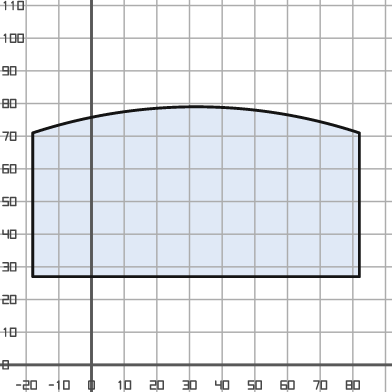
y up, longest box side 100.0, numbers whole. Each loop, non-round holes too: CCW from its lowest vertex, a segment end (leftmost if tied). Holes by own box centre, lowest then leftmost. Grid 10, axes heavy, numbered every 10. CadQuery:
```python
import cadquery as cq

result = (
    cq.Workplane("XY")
    .moveTo(-18.0, 27.0)
    .lineTo(82.0, 27.0)
    .lineTo(82.0, 71.0)
    .threePointArc((32.0, 79.0), (-18.0, 71.0))
    .close()
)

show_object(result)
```